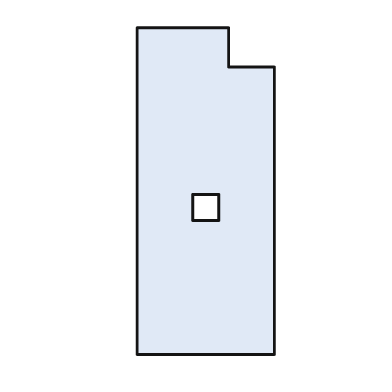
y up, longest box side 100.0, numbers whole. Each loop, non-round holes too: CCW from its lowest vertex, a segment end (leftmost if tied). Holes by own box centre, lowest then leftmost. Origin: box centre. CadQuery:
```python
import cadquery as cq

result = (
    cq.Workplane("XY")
    .moveTo(-21.0, -50.0)
    .lineTo(21.0, -50.0)
    .lineTo(21.0, 38.0)
    .lineTo(7.0, 38.0)
    .lineTo(7.0, 50.0)
    .lineTo(-21.0, 50.0)
    .close()
    .moveTo(-4.0, -9.0)
    .lineTo(4.0, -9.0)
    .lineTo(4.0, -1.0)
    .lineTo(-4.0, -1.0)
    .close()
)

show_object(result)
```